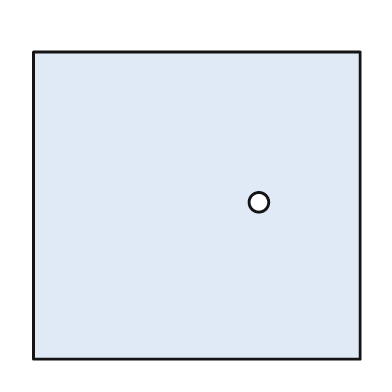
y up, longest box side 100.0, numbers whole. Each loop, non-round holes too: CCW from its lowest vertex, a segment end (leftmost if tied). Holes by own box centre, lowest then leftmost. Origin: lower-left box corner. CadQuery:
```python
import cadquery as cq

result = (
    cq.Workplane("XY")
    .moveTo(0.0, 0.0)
    .lineTo(100.0, 0.0)
    .lineTo(100.0, 94.0)
    .lineTo(0.0, 94.0)
    .close()
    .moveTo(69.0, 48.0)
    .circle(3.0)
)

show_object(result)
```